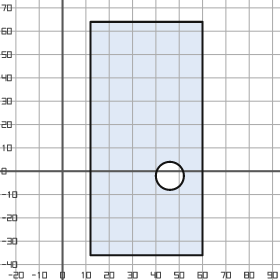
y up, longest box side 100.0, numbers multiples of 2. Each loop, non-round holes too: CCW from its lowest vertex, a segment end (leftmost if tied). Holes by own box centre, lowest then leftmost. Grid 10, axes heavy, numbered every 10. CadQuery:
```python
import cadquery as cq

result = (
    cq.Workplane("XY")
    .moveTo(12.0, -36.0)
    .lineTo(60.0, -36.0)
    .lineTo(60.0, 64.0)
    .lineTo(12.0, 64.0)
    .close()
    .moveTo(46.0, -2.0)
    .circle(6.0)
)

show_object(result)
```